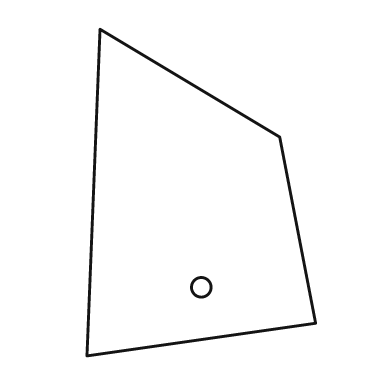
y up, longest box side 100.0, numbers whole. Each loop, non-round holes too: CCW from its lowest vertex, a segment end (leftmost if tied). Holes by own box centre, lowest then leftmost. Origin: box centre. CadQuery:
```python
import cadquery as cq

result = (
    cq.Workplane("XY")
    .moveTo(-35.0, -50.0)
    .lineTo(35.0, -40.0)
    .lineTo(24.0, 17.0)
    .lineTo(-31.0, 50.0)
    .close()
    .moveTo(0.0, -29.0)
    .circle(3.0)
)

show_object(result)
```